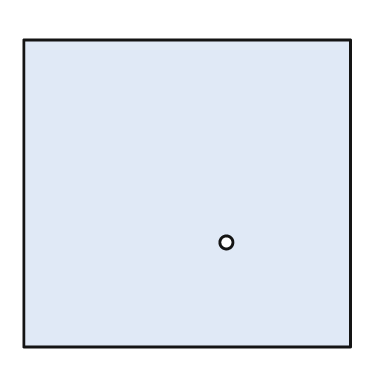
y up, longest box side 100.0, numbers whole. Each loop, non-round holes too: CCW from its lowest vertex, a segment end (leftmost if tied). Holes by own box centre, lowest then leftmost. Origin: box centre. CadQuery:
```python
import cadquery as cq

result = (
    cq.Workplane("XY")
    .moveTo(-50.0, -47.0)
    .lineTo(50.0, -47.0)
    .lineTo(50.0, 47.0)
    .lineTo(-50.0, 47.0)
    .close()
    .moveTo(12.0, -15.0)
    .circle(2.0)
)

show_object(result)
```